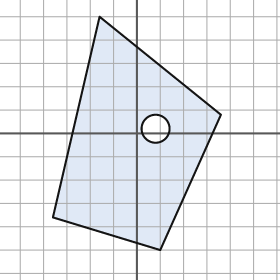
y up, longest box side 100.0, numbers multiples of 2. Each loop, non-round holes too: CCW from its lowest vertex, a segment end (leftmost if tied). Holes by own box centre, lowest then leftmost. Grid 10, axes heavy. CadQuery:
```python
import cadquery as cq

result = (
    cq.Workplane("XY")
    .moveTo(10.0, -50.0)
    .lineTo(36.0, 8.0)
    .lineTo(-16.0, 50.0)
    .lineTo(-36.0, -36.0)
    .close()
    .moveTo(8.0, 2.0)
    .circle(6.0)
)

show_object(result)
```